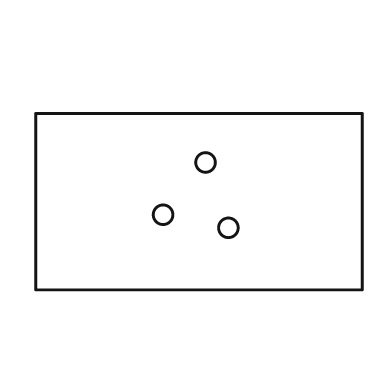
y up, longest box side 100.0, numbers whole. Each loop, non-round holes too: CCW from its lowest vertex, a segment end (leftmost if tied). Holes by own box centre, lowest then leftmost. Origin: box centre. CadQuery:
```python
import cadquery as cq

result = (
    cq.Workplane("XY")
    .moveTo(-50.0, -27.0)
    .lineTo(50.0, -27.0)
    .lineTo(50.0, 27.0)
    .lineTo(-50.0, 27.0)
    .close()
    .moveTo(9.0, -8.0)
    .circle(3.0)
    .moveTo(-11.0, -4.0)
    .circle(3.0)
    .moveTo(2.0, 12.0)
    .circle(3.0)
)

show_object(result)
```